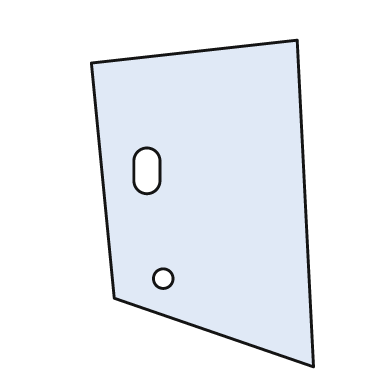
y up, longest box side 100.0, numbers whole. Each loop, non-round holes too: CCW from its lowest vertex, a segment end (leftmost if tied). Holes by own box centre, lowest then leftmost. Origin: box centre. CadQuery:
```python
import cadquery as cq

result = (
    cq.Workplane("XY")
    .moveTo(34.0, -50.0)
    .lineTo(29.0, 50.0)
    .lineTo(-34.0, 43.0)
    .lineTo(-27.0, -29.0)
    .close()
    .moveTo(-12.0, -23.0)
    .circle(3.0)
    .moveTo(-21.0, 7.0)
    .threePointArc((-17.0, 3.0), (-13.0, 7.0))
    .lineTo(-13.0, 13.0)
    .threePointArc((-17.0, 17.0), (-21.0, 13.0))
    .close()
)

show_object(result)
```